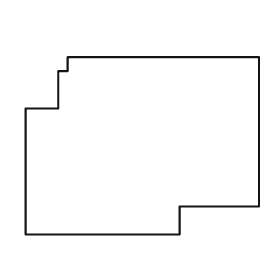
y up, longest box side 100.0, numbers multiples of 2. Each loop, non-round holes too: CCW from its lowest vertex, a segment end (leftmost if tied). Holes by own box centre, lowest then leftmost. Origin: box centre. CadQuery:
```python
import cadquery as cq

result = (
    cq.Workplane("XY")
    .moveTo(-50.0, -38.0)
    .lineTo(16.0, -38.0)
    .lineTo(16.0, -26.0)
    .lineTo(50.0, -26.0)
    .lineTo(50.0, 38.0)
    .lineTo(-32.0, 38.0)
    .lineTo(-32.0, 32.0)
    .lineTo(-36.0, 32.0)
    .lineTo(-36.0, 16.0)
    .lineTo(-50.0, 16.0)
    .close()
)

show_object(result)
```